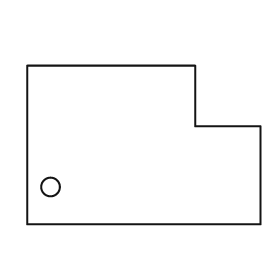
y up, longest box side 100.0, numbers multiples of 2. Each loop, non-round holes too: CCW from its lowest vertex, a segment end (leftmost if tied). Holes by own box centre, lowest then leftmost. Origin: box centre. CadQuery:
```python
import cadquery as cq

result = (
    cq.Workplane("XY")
    .moveTo(-50.0, -34.0)
    .lineTo(50.0, -34.0)
    .lineTo(50.0, 8.0)
    .lineTo(22.0, 8.0)
    .lineTo(22.0, 34.0)
    .lineTo(-50.0, 34.0)
    .close()
    .moveTo(-40.0, -18.0)
    .circle(4.0)
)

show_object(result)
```